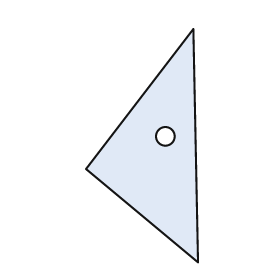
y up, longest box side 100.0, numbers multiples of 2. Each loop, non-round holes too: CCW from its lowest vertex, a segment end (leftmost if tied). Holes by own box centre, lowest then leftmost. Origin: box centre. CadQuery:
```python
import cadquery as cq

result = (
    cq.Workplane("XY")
    .moveTo(24.0, -50.0)
    .lineTo(22.0, 50.0)
    .lineTo(-24.0, -10.0)
    .close()
    .moveTo(10.0, 4.0)
    .circle(4.0)
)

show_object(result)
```